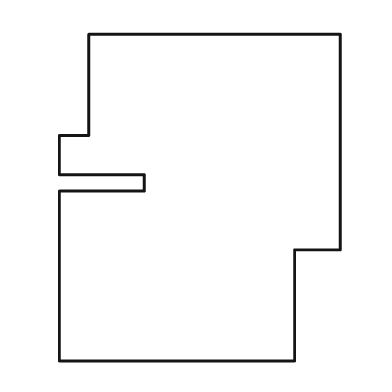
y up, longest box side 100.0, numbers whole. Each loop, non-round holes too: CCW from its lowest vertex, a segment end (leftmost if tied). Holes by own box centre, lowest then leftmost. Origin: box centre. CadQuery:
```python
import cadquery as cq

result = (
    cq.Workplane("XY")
    .moveTo(-43.0, -50.0)
    .lineTo(29.0, -50.0)
    .lineTo(29.0, -16.0)
    .lineTo(43.0, -16.0)
    .lineTo(43.0, 50.0)
    .lineTo(-34.0, 50.0)
    .lineTo(-34.0, 19.0)
    .lineTo(-43.0, 19.0)
    .lineTo(-43.0, 7.0)
    .lineTo(-17.0, 7.0)
    .lineTo(-17.0, 2.0)
    .lineTo(-43.0, 2.0)
    .close()
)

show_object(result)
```